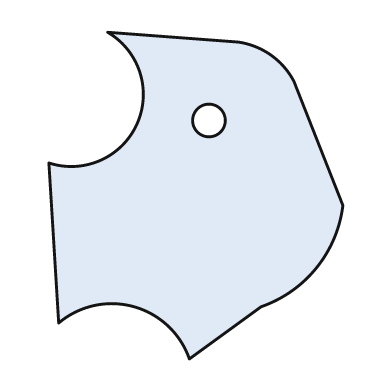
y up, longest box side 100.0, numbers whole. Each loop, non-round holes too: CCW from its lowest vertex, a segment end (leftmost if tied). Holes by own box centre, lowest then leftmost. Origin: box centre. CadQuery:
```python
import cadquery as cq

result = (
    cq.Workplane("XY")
    .moveTo(-2.0, -50.0)
    .lineTo(20.0, -34.0)
    .threePointArc((37.0, -22.0), (45.0, -3.0))
    .lineTo(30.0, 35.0)
    .threePointArc((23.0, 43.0), (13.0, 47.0))
    .lineTo(-27.0, 50.0)
    .threePointArc((-18.0, 22.0), (-45.0, 10.0))
    .lineTo(-42.0, -39.0)
    .threePointArc((-19.0, -34.0), (-2.0, -50.0))
    .close()
    .moveTo(4.0, 23.0)
    .circle(5.0)
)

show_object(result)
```